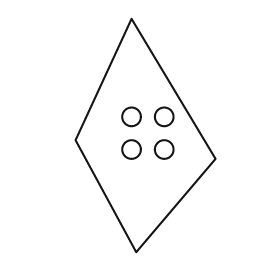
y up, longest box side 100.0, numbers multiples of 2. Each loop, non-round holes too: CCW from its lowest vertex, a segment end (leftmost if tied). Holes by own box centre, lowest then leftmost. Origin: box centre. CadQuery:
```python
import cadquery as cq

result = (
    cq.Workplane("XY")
    .moveTo(-4.0, -50.0)
    .lineTo(30.0, -10.0)
    .lineTo(-6.0, 50.0)
    .lineTo(-30.0, -2.0)
    .close()
    .moveTo(-6.0, -6.0)
    .circle(4.0)
    .moveTo(8.0, -6.0)
    .circle(4.0)
    .moveTo(-6.0, 8.0)
    .circle(4.0)
    .moveTo(8.0, 8.0)
    .circle(4.0)
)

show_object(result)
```